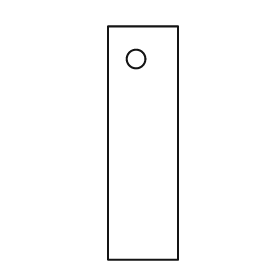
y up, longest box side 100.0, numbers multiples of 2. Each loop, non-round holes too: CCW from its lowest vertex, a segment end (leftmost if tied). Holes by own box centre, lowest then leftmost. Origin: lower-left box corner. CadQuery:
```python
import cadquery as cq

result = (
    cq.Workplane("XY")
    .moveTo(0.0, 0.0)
    .lineTo(30.0, 0.0)
    .lineTo(30.0, 100.0)
    .lineTo(0.0, 100.0)
    .close()
    .moveTo(12.0, 86.0)
    .circle(4.0)
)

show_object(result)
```